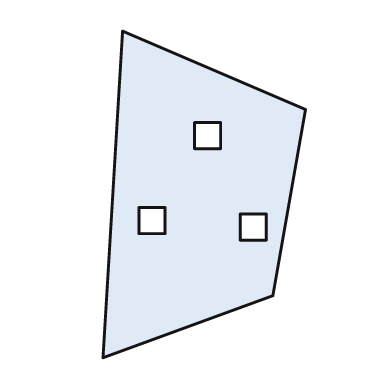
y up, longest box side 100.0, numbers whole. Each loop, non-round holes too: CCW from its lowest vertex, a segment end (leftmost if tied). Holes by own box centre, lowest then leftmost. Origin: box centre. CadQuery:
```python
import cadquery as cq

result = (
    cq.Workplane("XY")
    .moveTo(-31.0, -50.0)
    .lineTo(21.0, -31.0)
    .lineTo(31.0, 26.0)
    .lineTo(-25.0, 50.0)
    .close()
    .moveTo(11.0, -14.0)
    .lineTo(19.0, -14.0)
    .lineTo(19.0, -6.0)
    .lineTo(11.0, -6.0)
    .close()
    .moveTo(-20.0, -12.0)
    .lineTo(-12.0, -12.0)
    .lineTo(-12.0, -4.0)
    .lineTo(-20.0, -4.0)
    .close()
    .moveTo(-3.0, 14.0)
    .lineTo(5.0, 14.0)
    .lineTo(5.0, 22.0)
    .lineTo(-3.0, 22.0)
    .close()
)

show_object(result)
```